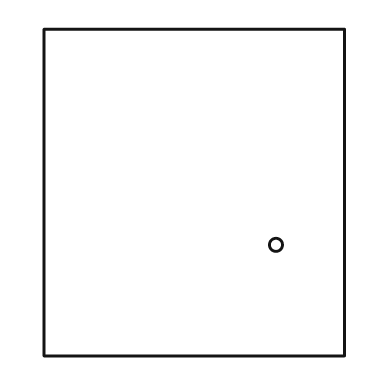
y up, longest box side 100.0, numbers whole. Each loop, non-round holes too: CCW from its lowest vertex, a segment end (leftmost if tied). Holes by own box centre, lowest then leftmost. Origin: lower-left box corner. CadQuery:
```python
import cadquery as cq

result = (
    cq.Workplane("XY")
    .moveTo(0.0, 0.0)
    .lineTo(92.0, 0.0)
    .lineTo(92.0, 100.0)
    .lineTo(0.0, 100.0)
    .close()
    .moveTo(71.0, 34.0)
    .circle(2.0)
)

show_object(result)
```